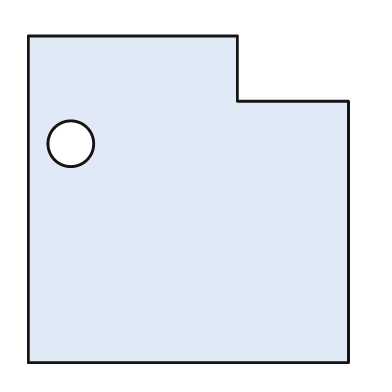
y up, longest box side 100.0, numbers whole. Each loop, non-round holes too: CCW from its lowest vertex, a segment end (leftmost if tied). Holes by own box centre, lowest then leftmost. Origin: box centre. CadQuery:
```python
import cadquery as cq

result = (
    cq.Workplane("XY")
    .moveTo(-49.0, -50.0)
    .lineTo(49.0, -50.0)
    .lineTo(49.0, 30.0)
    .lineTo(15.0, 30.0)
    .lineTo(15.0, 50.0)
    .lineTo(-49.0, 50.0)
    .close()
    .moveTo(-36.0, 17.0)
    .circle(7.0)
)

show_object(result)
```